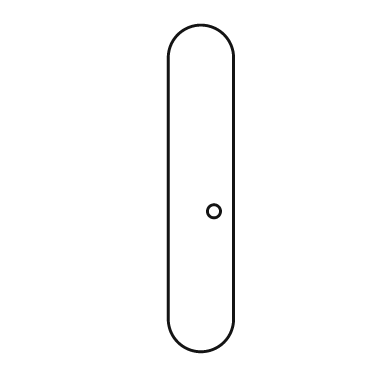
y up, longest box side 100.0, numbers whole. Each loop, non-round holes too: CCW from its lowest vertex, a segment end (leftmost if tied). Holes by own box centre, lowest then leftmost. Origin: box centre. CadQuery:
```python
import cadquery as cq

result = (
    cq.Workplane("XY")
    .moveTo(-10.0, -40.0)
    .threePointArc((0.0, -50.0), (10.0, -40.0))
    .lineTo(10.0, 40.0)
    .threePointArc((0.0, 50.0), (-10.0, 40.0))
    .close()
    .moveTo(4.0, -7.0)
    .circle(2.0)
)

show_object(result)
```